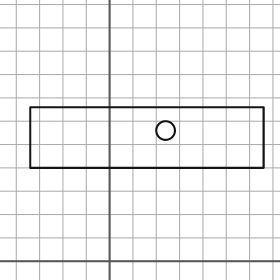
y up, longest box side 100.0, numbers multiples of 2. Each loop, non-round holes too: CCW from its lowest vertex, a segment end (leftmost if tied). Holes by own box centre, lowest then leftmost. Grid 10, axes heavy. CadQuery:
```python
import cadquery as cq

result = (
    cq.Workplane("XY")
    .moveTo(-34.0, 40.0)
    .lineTo(66.0, 40.0)
    .lineTo(66.0, 66.0)
    .lineTo(-34.0, 66.0)
    .close()
    .moveTo(24.0, 56.0)
    .circle(4.0)
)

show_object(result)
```